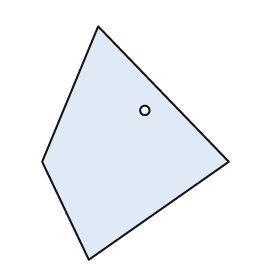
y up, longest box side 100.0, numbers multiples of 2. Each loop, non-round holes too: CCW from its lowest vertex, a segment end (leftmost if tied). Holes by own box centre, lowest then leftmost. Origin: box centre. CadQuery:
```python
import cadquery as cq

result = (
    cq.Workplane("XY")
    .moveTo(-20.0, -50.0)
    .lineTo(40.0, -8.0)
    .lineTo(-16.0, 50.0)
    .lineTo(-40.0, -8.0)
    .close()
    .moveTo(4.0, 14.0)
    .circle(2.0)
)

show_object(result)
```